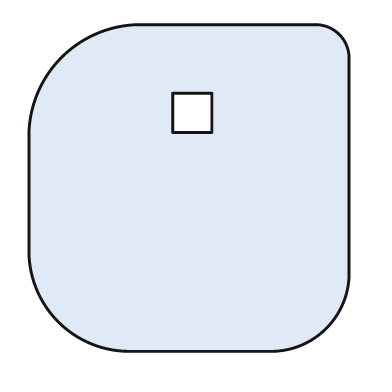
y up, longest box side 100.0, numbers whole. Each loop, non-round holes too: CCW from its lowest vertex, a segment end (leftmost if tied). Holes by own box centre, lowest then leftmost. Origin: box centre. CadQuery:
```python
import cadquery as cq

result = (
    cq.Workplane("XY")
    .moveTo(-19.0, -50.0)
    .lineTo(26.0, -50.0)
    .threePointArc((42.0, -43.0), (49.0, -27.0))
    .lineTo(49.0, 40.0)
    .threePointArc((46.0, 47.0), (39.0, 50.0))
    .lineTo(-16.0, 50.0)
    .threePointArc((-39.0, 40.0), (-49.0, 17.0))
    .lineTo(-49.0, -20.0)
    .threePointArc((-40.0, -41.0), (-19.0, -50.0))
    .close()
    .moveTo(-5.0, 17.0)
    .lineTo(7.0, 17.0)
    .lineTo(7.0, 29.0)
    .lineTo(-5.0, 29.0)
    .close()
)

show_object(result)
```